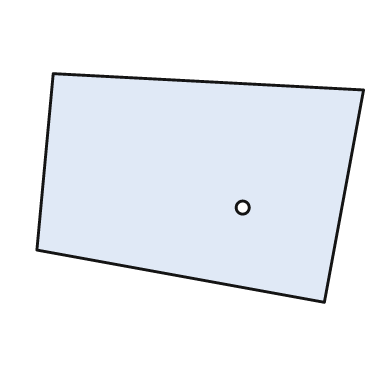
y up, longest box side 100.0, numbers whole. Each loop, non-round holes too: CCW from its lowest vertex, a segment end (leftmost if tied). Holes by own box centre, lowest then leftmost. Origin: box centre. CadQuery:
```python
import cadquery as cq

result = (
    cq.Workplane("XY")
    .moveTo(38.0, -35.0)
    .lineTo(50.0, 30.0)
    .lineTo(-45.0, 35.0)
    .lineTo(-50.0, -19.0)
    .close()
    .moveTo(13.0, -6.0)
    .circle(2.0)
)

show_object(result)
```